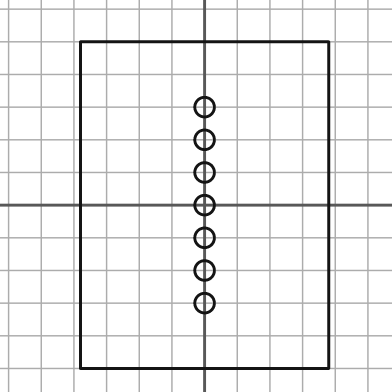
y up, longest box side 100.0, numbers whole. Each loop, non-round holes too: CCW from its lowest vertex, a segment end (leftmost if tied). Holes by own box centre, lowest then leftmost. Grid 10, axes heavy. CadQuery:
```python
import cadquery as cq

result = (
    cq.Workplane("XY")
    .moveTo(-38.0, -50.0)
    .lineTo(38.0, -50.0)
    .lineTo(38.0, 50.0)
    .lineTo(-38.0, 50.0)
    .close()
    .moveTo(0.0, -30.0)
    .circle(3.0)
    .moveTo(0.0, -20.0)
    .circle(3.0)
    .moveTo(0.0, -10.0)
    .circle(3.0)
    .moveTo(0.0, 0.0)
    .circle(3.0)
    .moveTo(0.0, 10.0)
    .circle(3.0)
    .moveTo(0.0, 20.0)
    .circle(3.0)
    .moveTo(0.0, 30.0)
    .circle(3.0)
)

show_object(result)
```